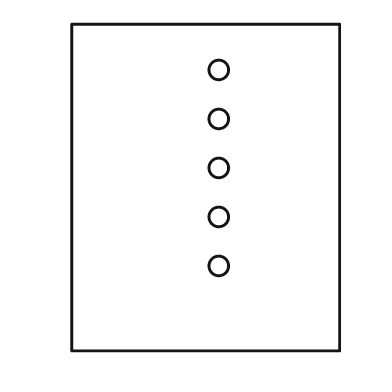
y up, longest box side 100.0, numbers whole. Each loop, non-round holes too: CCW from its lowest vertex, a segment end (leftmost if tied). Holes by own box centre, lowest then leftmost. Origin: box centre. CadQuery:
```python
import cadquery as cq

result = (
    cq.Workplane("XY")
    .moveTo(-41.0, -50.0)
    .lineTo(41.0, -50.0)
    .lineTo(41.0, 50.0)
    .lineTo(-41.0, 50.0)
    .close()
    .moveTo(4.0, -24.0)
    .circle(3.0)
    .moveTo(4.0, -9.0)
    .circle(3.0)
    .moveTo(4.0, 6.0)
    .circle(3.0)
    .moveTo(4.0, 21.0)
    .circle(3.0)
    .moveTo(4.0, 36.0)
    .circle(3.0)
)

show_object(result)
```